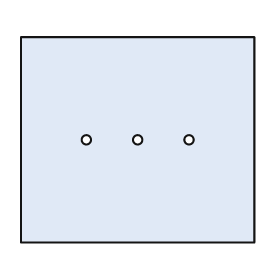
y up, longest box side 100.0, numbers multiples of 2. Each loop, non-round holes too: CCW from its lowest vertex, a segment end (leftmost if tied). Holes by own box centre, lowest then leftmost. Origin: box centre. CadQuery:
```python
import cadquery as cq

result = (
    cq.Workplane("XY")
    .moveTo(-50.0, -44.0)
    .lineTo(50.0, -44.0)
    .lineTo(50.0, 44.0)
    .lineTo(-50.0, 44.0)
    .close()
    .moveTo(-22.0, 0.0)
    .circle(2.0)
    .moveTo(0.0, 0.0)
    .circle(2.0)
    .moveTo(22.0, 0.0)
    .circle(2.0)
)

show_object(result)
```